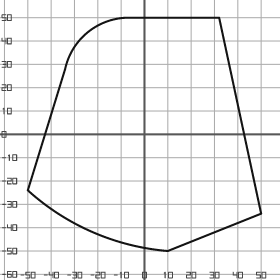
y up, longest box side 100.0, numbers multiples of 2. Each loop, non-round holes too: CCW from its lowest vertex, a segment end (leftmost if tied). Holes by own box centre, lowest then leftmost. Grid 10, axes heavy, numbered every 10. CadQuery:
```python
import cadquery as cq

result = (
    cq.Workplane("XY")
    .moveTo(10.0, -50.0)
    .lineTo(50.0, -34.0)
    .lineTo(32.0, 50.0)
    .lineTo(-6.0, 50.0)
    .threePointArc((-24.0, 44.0), (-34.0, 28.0))
    .lineTo(-50.0, -24.0)
    .threePointArc((-22.0, -42.0), (10.0, -50.0))
    .close()
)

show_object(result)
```